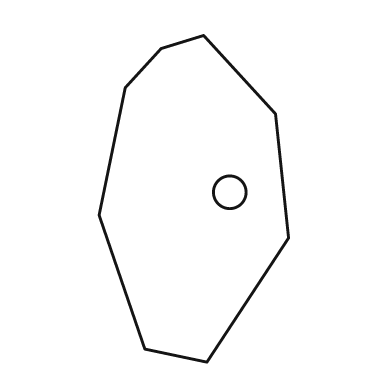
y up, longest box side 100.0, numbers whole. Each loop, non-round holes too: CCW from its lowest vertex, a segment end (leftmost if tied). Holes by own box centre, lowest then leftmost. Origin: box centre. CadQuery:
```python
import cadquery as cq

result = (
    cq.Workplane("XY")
    .moveTo(4.0, -50.0)
    .lineTo(29.0, -12.0)
    .lineTo(25.0, 26.0)
    .lineTo(3.0, 50.0)
    .lineTo(-10.0, 46.0)
    .lineTo(-21.0, 34.0)
    .lineTo(-29.0, -5.0)
    .lineTo(-15.0, -46.0)
    .close()
    .moveTo(11.0, 2.0)
    .circle(5.0)
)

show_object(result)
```